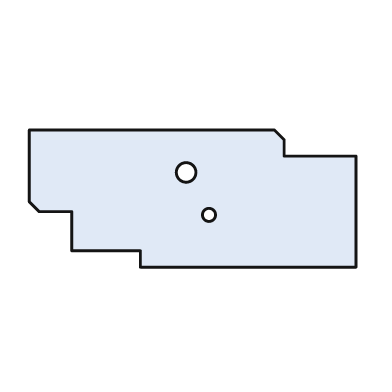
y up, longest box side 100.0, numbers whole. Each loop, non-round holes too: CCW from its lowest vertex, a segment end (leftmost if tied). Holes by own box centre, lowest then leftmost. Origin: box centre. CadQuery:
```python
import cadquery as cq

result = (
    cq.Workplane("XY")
    .moveTo(-16.0, -21.0)
    .lineTo(50.0, -21.0)
    .lineTo(50.0, 13.0)
    .lineTo(28.0, 13.0)
    .lineTo(28.0, 18.0)
    .lineTo(25.0, 21.0)
    .lineTo(-50.0, 21.0)
    .lineTo(-50.0, -1.0)
    .lineTo(-47.0, -4.0)
    .lineTo(-37.0, -4.0)
    .lineTo(-37.0, -16.0)
    .lineTo(-16.0, -16.0)
    .close()
    .moveTo(5.0, -5.0)
    .circle(2.0)
    .moveTo(-2.0, 8.0)
    .circle(3.0)
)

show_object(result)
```